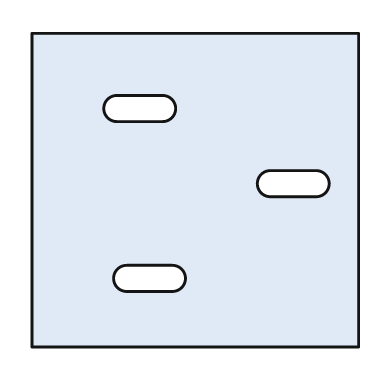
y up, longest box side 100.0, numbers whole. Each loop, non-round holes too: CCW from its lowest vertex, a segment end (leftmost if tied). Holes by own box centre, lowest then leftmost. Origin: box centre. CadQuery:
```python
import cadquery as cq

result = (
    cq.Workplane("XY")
    .moveTo(-50.0, -48.0)
    .lineTo(50.0, -48.0)
    .lineTo(50.0, 48.0)
    .lineTo(-50.0, 48.0)
    .close()
    .moveTo(-21.0, -31.0)
    .lineTo(-7.0, -31.0)
    .threePointArc((-3.0, -27.0), (-7.0, -23.0))
    .lineTo(-21.0, -23.0)
    .threePointArc((-25.0, -27.0), (-21.0, -31.0))
    .close()
    .moveTo(23.0, -2.0)
    .lineTo(37.0, -2.0)
    .threePointArc((41.0, 2.0), (37.0, 6.0))
    .lineTo(23.0, 6.0)
    .threePointArc((19.0, 2.0), (23.0, -2.0))
    .close()
    .moveTo(-24.0, 21.0)
    .lineTo(-10.0, 21.0)
    .threePointArc((-6.0, 25.0), (-10.0, 29.0))
    .lineTo(-24.0, 29.0)
    .threePointArc((-28.0, 25.0), (-24.0, 21.0))
    .close()
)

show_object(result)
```